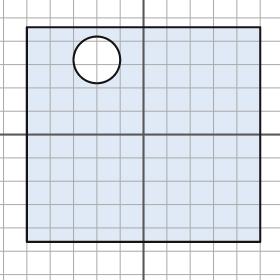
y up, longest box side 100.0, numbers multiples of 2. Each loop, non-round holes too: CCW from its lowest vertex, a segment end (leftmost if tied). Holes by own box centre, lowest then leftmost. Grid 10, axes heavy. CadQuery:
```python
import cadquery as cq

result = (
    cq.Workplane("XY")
    .moveTo(-50.0, -46.0)
    .lineTo(50.0, -46.0)
    .lineTo(50.0, 46.0)
    .lineTo(-50.0, 46.0)
    .close()
    .moveTo(-20.0, 32.0)
    .circle(10.0)
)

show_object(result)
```